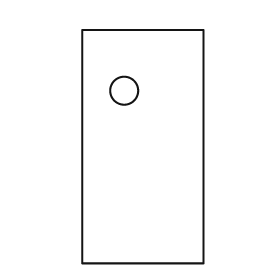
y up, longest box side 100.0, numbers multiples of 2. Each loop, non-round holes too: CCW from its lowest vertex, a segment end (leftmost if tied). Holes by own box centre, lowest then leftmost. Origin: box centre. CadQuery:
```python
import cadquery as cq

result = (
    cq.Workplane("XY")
    .moveTo(-26.0, -50.0)
    .lineTo(26.0, -50.0)
    .lineTo(26.0, 50.0)
    .lineTo(-26.0, 50.0)
    .close()
    .moveTo(-8.0, 24.0)
    .circle(6.0)
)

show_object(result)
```